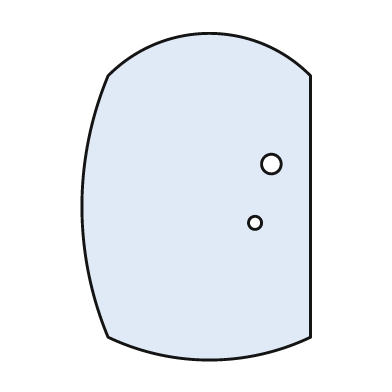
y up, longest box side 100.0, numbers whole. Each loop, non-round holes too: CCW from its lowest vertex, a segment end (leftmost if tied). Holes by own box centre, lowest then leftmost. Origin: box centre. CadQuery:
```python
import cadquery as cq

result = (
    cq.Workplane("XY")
    .moveTo(-27.0, -43.0)
    .threePointArc((4.0, -50.0), (35.0, -43.0))
    .lineTo(35.0, 37.0)
    .threePointArc((4.0, 50.0), (-27.0, 37.0))
    .threePointArc((-35.0, -3.0), (-27.0, -43.0))
    .close()
    .moveTo(18.0, -8.0)
    .circle(2.0)
    .moveTo(23.0, 10.0)
    .circle(3.0)
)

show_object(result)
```